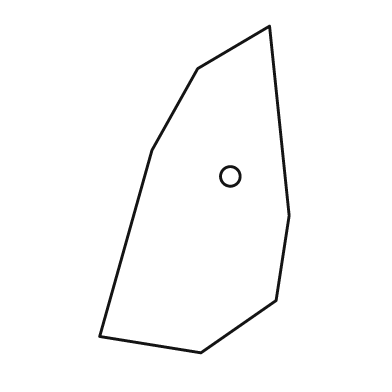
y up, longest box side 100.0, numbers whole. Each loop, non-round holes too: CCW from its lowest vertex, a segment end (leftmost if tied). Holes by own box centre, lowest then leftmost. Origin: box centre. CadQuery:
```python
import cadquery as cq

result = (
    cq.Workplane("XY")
    .moveTo(2.0, -50.0)
    .lineTo(25.0, -34.0)
    .lineTo(29.0, -8.0)
    .lineTo(23.0, 50.0)
    .lineTo(1.0, 37.0)
    .lineTo(-13.0, 12.0)
    .lineTo(-29.0, -45.0)
    .close()
    .moveTo(11.0, 4.0)
    .circle(3.0)
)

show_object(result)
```